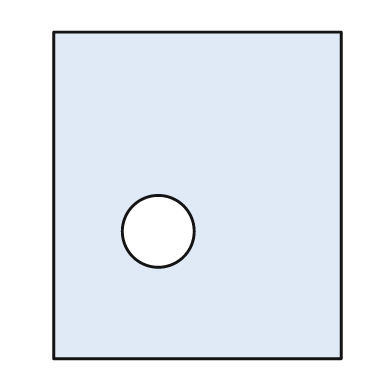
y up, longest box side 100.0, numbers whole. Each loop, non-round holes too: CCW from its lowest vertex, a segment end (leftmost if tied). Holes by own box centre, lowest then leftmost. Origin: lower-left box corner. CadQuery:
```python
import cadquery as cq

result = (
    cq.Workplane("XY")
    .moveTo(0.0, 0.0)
    .lineTo(88.0, 0.0)
    .lineTo(88.0, 100.0)
    .lineTo(0.0, 100.0)
    .close()
    .moveTo(32.0, 39.0)
    .circle(11.0)
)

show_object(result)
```